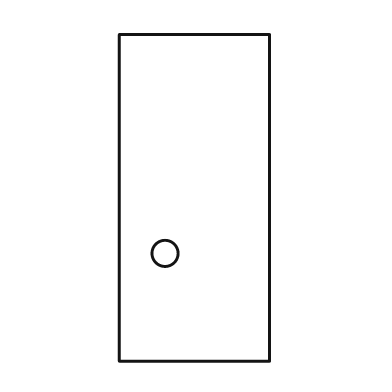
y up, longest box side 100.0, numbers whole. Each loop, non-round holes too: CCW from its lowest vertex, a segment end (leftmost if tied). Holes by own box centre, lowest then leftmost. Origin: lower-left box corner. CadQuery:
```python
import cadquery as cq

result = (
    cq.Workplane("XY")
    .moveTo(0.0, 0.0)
    .lineTo(46.0, 0.0)
    .lineTo(46.0, 100.0)
    .lineTo(0.0, 100.0)
    .close()
    .moveTo(14.0, 33.0)
    .circle(4.0)
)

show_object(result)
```